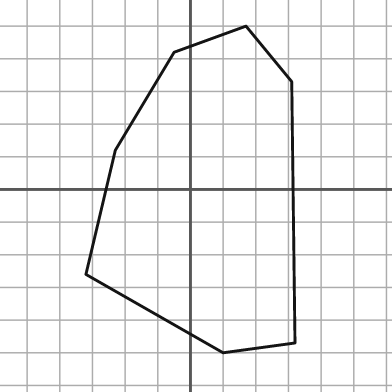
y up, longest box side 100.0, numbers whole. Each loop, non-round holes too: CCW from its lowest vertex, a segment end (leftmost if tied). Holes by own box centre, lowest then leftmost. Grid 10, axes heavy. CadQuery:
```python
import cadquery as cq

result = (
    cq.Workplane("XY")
    .moveTo(10.0, -50.0)
    .lineTo(32.0, -47.0)
    .lineTo(31.0, 33.0)
    .lineTo(17.0, 50.0)
    .lineTo(-5.0, 42.0)
    .lineTo(-23.0, 12.0)
    .lineTo(-32.0, -26.0)
    .close()
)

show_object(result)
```